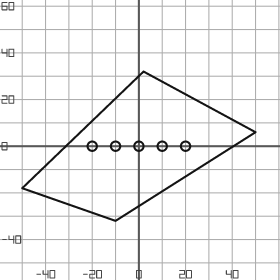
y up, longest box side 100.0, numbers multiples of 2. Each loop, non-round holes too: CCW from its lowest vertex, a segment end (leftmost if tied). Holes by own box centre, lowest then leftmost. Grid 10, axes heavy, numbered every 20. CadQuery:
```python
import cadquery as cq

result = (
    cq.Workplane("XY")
    .moveTo(-10.0, -32.0)
    .lineTo(50.0, 6.0)
    .lineTo(2.0, 32.0)
    .lineTo(-50.0, -18.0)
    .close()
    .moveTo(-20.0, 0.0)
    .circle(2.0)
    .moveTo(-10.0, 0.0)
    .circle(2.0)
    .moveTo(0.0, 0.0)
    .circle(2.0)
    .moveTo(10.0, 0.0)
    .circle(2.0)
    .moveTo(20.0, 0.0)
    .circle(2.0)
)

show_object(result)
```